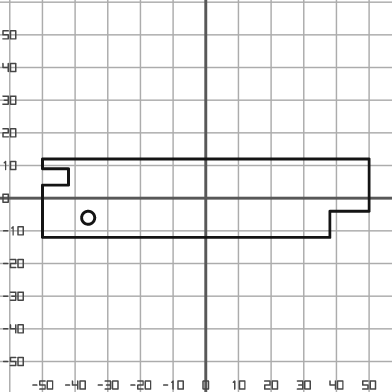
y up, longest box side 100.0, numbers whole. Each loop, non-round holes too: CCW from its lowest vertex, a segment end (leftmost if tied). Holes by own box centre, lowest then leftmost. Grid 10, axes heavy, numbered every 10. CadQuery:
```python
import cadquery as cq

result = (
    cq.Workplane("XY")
    .moveTo(-50.0, -12.0)
    .lineTo(38.0, -12.0)
    .lineTo(38.0, -4.0)
    .lineTo(50.0, -4.0)
    .lineTo(50.0, 12.0)
    .lineTo(-50.0, 12.0)
    .lineTo(-50.0, 9.0)
    .lineTo(-42.0, 9.0)
    .lineTo(-42.0, 4.0)
    .lineTo(-50.0, 4.0)
    .close()
    .moveTo(-36.0, -6.0)
    .circle(2.0)
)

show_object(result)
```